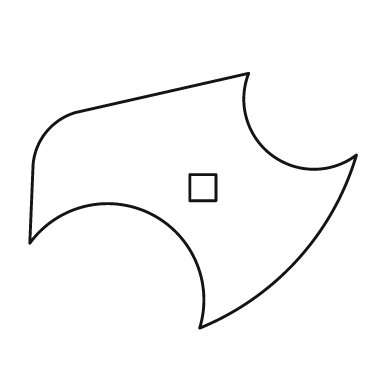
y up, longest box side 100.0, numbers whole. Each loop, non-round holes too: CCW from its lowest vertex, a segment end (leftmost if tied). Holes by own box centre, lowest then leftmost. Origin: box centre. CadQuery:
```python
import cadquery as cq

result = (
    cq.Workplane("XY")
    .moveTo(2.0, -39.0)
    .threePointArc((32.0, -18.0), (50.0, 14.0))
    .threePointArc((24.0, 14.0), (17.0, 39.0))
    .lineTo(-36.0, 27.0)
    .threePointArc((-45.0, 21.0), (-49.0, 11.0))
    .lineTo(-50.0, -13.0)
    .threePointArc((-13.0, -4.0), (2.0, -39.0))
    .close()
    .moveTo(-1.0, 0.0)
    .lineTo(7.0, 0.0)
    .lineTo(7.0, 8.0)
    .lineTo(-1.0, 8.0)
    .close()
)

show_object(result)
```